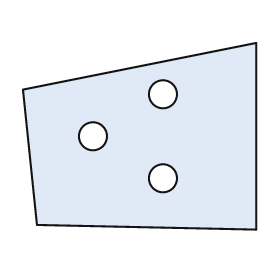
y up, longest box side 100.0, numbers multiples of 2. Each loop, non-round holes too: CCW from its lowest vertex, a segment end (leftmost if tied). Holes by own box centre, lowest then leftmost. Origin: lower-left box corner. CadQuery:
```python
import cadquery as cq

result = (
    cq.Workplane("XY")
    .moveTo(100.0, 0.0)
    .lineTo(100.0, 80.0)
    .lineTo(0.0, 60.0)
    .lineTo(6.0, 2.0)
    .close()
    .moveTo(60.0, 22.0)
    .circle(6.0)
    .moveTo(30.0, 40.0)
    .circle(6.0)
    .moveTo(60.0, 58.0)
    .circle(6.0)
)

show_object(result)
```